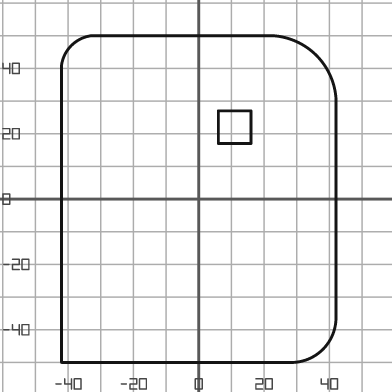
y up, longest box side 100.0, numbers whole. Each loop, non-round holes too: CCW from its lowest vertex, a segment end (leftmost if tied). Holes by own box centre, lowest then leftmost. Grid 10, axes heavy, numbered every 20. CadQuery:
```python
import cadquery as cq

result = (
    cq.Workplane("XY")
    .moveTo(-42.0, -50.0)
    .lineTo(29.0, -50.0)
    .threePointArc((38.0, -46.0), (42.0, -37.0))
    .lineTo(42.0, 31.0)
    .threePointArc((36.0, 44.0), (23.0, 50.0))
    .lineTo(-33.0, 50.0)
    .threePointArc((-39.0, 47.0), (-42.0, 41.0))
    .close()
    .moveTo(6.0, 17.0)
    .lineTo(16.0, 17.0)
    .lineTo(16.0, 27.0)
    .lineTo(6.0, 27.0)
    .close()
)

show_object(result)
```